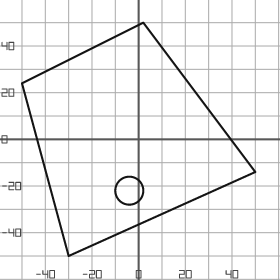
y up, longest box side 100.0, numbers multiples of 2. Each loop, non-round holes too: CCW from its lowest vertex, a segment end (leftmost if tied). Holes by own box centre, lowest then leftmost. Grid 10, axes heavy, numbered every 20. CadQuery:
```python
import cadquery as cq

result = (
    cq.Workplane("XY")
    .moveTo(-30.0, -50.0)
    .lineTo(50.0, -14.0)
    .lineTo(2.0, 50.0)
    .lineTo(-50.0, 24.0)
    .close()
    .moveTo(-4.0, -22.0)
    .circle(6.0)
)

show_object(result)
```